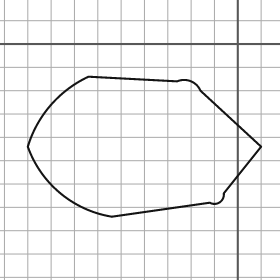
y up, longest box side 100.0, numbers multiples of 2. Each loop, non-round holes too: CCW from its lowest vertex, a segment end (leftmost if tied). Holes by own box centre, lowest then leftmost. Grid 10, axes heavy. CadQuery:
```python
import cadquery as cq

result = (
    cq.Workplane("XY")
    .moveTo(-54.0, -74.0)
    .lineTo(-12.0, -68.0)
    .threePointArc((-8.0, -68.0), (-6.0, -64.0))
    .lineTo(10.0, -44.0)
    .lineTo(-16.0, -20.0)
    .threePointArc((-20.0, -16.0), (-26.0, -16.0))
    .lineTo(-64.0, -14.0)
    .threePointArc((-80.0, -26.0), (-90.0, -44.0))
    .threePointArc((-76.0, -64.0), (-54.0, -74.0))
    .close()
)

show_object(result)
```